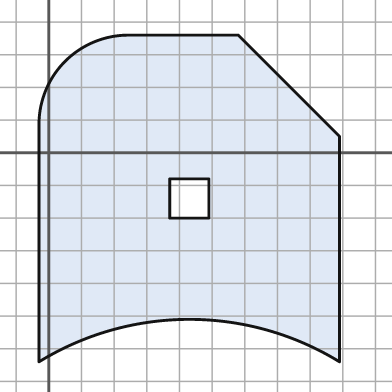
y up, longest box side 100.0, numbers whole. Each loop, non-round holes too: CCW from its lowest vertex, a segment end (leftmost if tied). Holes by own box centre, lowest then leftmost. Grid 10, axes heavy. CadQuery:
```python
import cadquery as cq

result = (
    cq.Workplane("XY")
    .moveTo(-3.0, -64.0)
    .threePointArc((43.0, -51.0), (89.0, -64.0))
    .lineTo(89.0, 5.0)
    .lineTo(58.0, 36.0)
    .lineTo(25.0, 36.0)
    .threePointArc((5.0, 28.0), (-3.0, 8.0))
    .close()
    .moveTo(37.0, -20.0)
    .lineTo(49.0, -20.0)
    .lineTo(49.0, -8.0)
    .lineTo(37.0, -8.0)
    .close()
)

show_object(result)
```